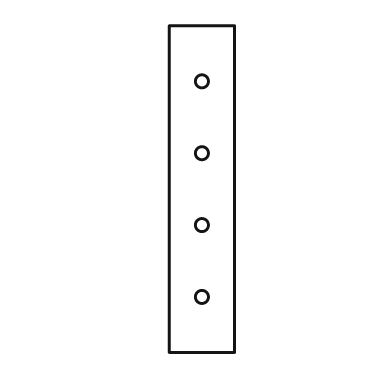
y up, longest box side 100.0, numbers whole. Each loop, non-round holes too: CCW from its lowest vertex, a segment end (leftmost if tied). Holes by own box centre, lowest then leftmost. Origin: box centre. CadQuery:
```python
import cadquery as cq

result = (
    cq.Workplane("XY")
    .moveTo(-10.0, -50.0)
    .lineTo(10.0, -50.0)
    .lineTo(10.0, 50.0)
    .lineTo(-10.0, 50.0)
    .close()
    .moveTo(0.0, -33.0)
    .circle(2.0)
    .moveTo(0.0, -11.0)
    .circle(2.0)
    .moveTo(0.0, 11.0)
    .circle(2.0)
    .moveTo(0.0, 33.0)
    .circle(2.0)
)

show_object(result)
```